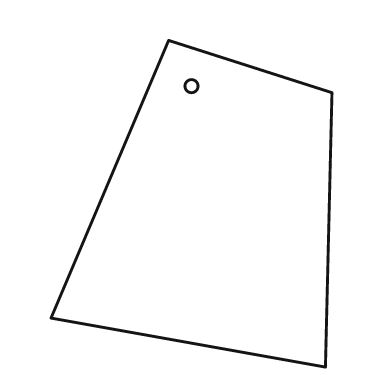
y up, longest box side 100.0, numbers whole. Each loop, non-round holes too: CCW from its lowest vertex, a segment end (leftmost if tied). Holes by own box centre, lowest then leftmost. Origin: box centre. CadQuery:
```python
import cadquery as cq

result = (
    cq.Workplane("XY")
    .moveTo(41.0, -50.0)
    .lineTo(43.0, 34.0)
    .lineTo(-7.0, 50.0)
    .lineTo(-43.0, -35.0)
    .close()
    .moveTo(0.0, 36.0)
    .circle(2.0)
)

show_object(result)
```